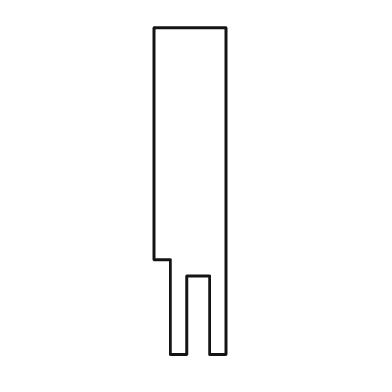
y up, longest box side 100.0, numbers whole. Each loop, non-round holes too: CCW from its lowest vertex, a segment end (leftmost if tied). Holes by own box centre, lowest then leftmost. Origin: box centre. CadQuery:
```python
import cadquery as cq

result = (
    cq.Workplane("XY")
    .moveTo(-6.0, -50.0)
    .lineTo(-1.0, -50.0)
    .lineTo(-1.0, -26.0)
    .lineTo(6.0, -26.0)
    .lineTo(6.0, -50.0)
    .lineTo(11.0, -50.0)
    .lineTo(11.0, 50.0)
    .lineTo(-11.0, 50.0)
    .lineTo(-11.0, -21.0)
    .lineTo(-6.0, -21.0)
    .close()
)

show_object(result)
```